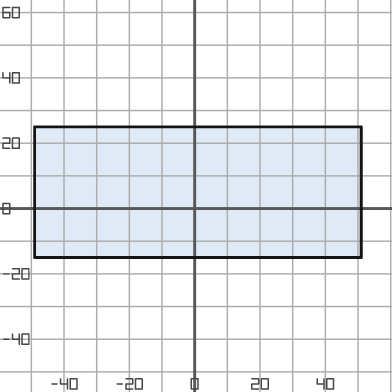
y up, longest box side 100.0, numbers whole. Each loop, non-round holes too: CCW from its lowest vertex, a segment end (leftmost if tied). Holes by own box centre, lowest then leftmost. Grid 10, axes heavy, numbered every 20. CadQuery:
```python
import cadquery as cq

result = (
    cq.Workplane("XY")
    .moveTo(-49.0, -15.0)
    .lineTo(51.0, -15.0)
    .lineTo(51.0, 25.0)
    .lineTo(-49.0, 25.0)
    .close()
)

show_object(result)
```